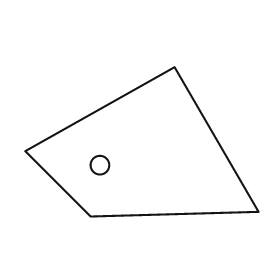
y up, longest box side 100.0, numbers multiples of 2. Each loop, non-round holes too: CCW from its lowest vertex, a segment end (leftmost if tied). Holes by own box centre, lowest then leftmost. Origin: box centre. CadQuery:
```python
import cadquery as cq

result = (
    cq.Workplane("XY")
    .moveTo(-22.0, -32.0)
    .lineTo(50.0, -30.0)
    .lineTo(14.0, 32.0)
    .lineTo(-50.0, -4.0)
    .close()
    .moveTo(-18.0, -10.0)
    .circle(4.0)
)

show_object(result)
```